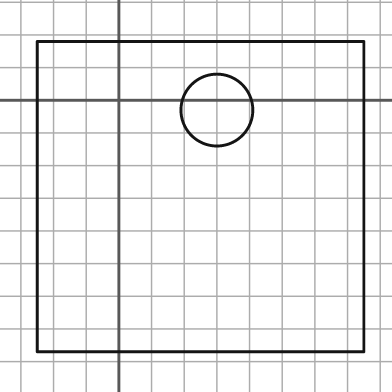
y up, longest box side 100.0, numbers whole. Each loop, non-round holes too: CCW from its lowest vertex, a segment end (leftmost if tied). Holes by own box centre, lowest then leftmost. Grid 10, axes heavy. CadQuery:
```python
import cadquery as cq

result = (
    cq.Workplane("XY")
    .moveTo(-25.0, -77.0)
    .lineTo(75.0, -77.0)
    .lineTo(75.0, 18.0)
    .lineTo(-25.0, 18.0)
    .close()
    .moveTo(30.0, -3.0)
    .circle(11.0)
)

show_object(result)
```